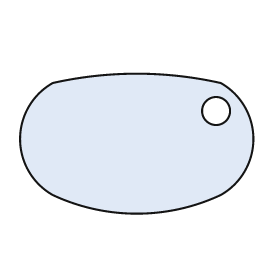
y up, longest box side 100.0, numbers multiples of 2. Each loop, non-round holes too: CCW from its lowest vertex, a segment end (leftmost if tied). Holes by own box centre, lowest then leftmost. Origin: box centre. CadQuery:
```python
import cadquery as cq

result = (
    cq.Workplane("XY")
    .moveTo(-36.0, -22.0)
    .threePointArc((0.0, -30.0), (36.0, -22.0))
    .threePointArc((50.0, 2.0), (36.0, 26.0))
    .threePointArc((0.0, 30.0), (-36.0, 26.0))
    .threePointArc((-50.0, 2.0), (-36.0, -22.0))
    .close()
    .moveTo(34.0, 14.0)
    .circle(6.0)
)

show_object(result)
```